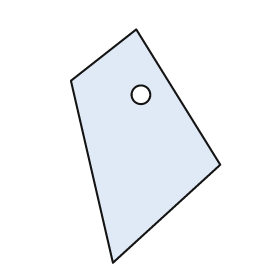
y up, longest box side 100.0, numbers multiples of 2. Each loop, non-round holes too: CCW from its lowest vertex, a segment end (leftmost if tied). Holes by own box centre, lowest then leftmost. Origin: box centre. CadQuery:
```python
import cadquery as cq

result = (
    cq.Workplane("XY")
    .moveTo(-14.0, -50.0)
    .lineTo(32.0, -8.0)
    .lineTo(-4.0, 50.0)
    .lineTo(-32.0, 28.0)
    .close()
    .moveTo(-2.0, 22.0)
    .circle(4.0)
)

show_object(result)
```